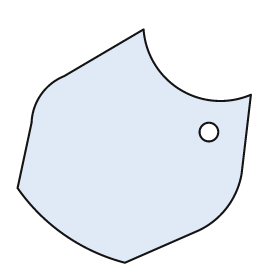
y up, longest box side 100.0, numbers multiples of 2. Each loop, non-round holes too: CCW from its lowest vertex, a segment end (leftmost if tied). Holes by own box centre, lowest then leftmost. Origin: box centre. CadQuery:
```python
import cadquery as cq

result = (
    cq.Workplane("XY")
    .moveTo(-4.0, -50.0)
    .lineTo(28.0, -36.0)
    .threePointArc((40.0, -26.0), (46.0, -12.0))
    .lineTo(50.0, 22.0)
    .threePointArc((20.0, 24.0), (4.0, 50.0))
    .lineTo(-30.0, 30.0)
    .threePointArc((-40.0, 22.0), (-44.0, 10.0))
    .lineTo(-50.0, -18.0)
    .threePointArc((-30.0, -38.0), (-4.0, -50.0))
    .close()
    .moveTo(32.0, 6.0)
    .circle(4.0)
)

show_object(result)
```